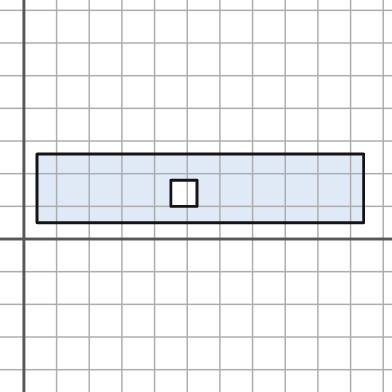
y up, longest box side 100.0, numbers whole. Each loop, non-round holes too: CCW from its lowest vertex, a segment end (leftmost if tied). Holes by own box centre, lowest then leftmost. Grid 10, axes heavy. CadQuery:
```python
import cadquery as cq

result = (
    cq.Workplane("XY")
    .moveTo(4.0, 5.0)
    .lineTo(104.0, 5.0)
    .lineTo(104.0, 26.0)
    .lineTo(4.0, 26.0)
    .close()
    .moveTo(45.0, 10.0)
    .lineTo(53.0, 10.0)
    .lineTo(53.0, 18.0)
    .lineTo(45.0, 18.0)
    .close()
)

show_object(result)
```